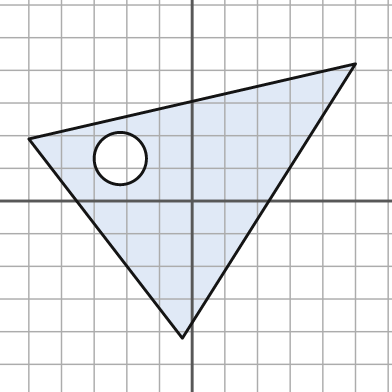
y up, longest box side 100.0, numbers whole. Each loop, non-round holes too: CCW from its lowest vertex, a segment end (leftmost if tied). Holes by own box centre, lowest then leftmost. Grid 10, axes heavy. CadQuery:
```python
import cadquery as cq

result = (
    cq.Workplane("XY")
    .moveTo(-3.0, -42.0)
    .lineTo(50.0, 42.0)
    .lineTo(-50.0, 19.0)
    .close()
    .moveTo(-22.0, 13.0)
    .circle(8.0)
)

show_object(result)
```